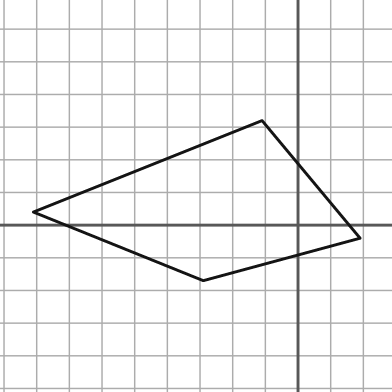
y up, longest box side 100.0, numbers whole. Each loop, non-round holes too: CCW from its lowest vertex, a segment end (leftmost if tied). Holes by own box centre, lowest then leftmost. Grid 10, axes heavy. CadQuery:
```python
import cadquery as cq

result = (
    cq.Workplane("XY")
    .moveTo(-29.0, -17.0)
    .lineTo(19.0, -4.0)
    .lineTo(-11.0, 32.0)
    .lineTo(-81.0, 4.0)
    .close()
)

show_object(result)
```